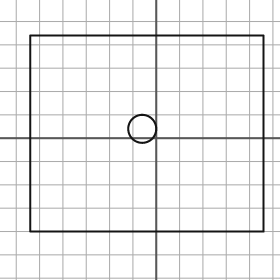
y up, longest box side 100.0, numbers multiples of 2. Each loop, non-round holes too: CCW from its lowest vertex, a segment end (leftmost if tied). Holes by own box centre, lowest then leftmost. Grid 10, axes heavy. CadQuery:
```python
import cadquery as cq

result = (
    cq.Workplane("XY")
    .moveTo(-54.0, -40.0)
    .lineTo(46.0, -40.0)
    .lineTo(46.0, 44.0)
    .lineTo(-54.0, 44.0)
    .close()
    .moveTo(-6.0, 4.0)
    .circle(6.0)
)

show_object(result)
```